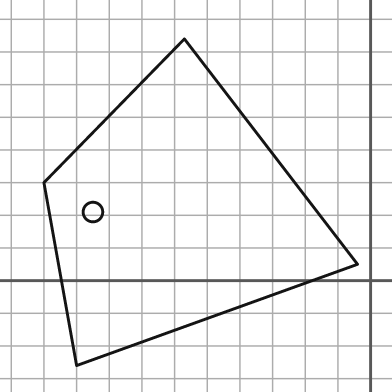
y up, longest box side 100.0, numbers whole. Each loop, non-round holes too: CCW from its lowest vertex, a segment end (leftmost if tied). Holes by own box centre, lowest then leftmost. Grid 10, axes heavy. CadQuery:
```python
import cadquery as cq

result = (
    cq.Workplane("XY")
    .moveTo(-90.0, -26.0)
    .lineTo(-4.0, 5.0)
    .lineTo(-57.0, 74.0)
    .lineTo(-100.0, 30.0)
    .close()
    .moveTo(-85.0, 21.0)
    .circle(3.0)
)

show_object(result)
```